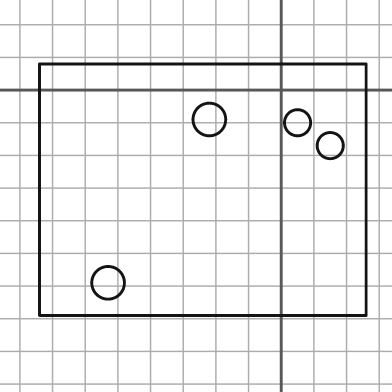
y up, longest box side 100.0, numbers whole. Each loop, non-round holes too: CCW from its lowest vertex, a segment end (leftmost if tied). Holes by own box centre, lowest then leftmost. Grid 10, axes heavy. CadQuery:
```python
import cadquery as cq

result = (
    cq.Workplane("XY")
    .moveTo(-74.0, -69.0)
    .lineTo(26.0, -69.0)
    .lineTo(26.0, 8.0)
    .lineTo(-74.0, 8.0)
    .close()
    .moveTo(-53.0, -59.0)
    .circle(5.0)
    .moveTo(15.0, -17.0)
    .circle(4.0)
    .moveTo(5.0, -10.0)
    .circle(4.0)
    .moveTo(-22.0, -9.0)
    .circle(5.0)
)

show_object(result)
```